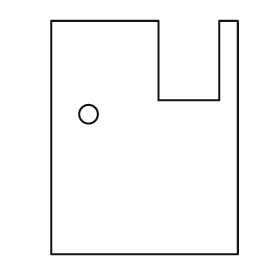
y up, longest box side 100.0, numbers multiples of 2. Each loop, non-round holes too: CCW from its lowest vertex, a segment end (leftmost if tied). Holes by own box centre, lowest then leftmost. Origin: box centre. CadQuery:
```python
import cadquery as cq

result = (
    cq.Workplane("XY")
    .moveTo(-40.0, -50.0)
    .lineTo(40.0, -50.0)
    .lineTo(40.0, 50.0)
    .lineTo(32.0, 50.0)
    .lineTo(32.0, 16.0)
    .lineTo(6.0, 16.0)
    .lineTo(6.0, 50.0)
    .lineTo(-40.0, 50.0)
    .close()
    .moveTo(-24.0, 10.0)
    .circle(4.0)
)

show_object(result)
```